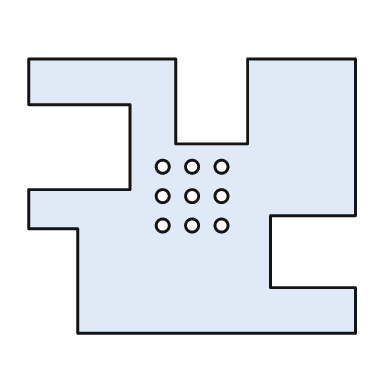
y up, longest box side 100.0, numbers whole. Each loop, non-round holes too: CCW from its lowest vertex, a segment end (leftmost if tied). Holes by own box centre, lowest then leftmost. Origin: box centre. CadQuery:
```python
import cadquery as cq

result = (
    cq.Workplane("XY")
    .moveTo(-35.0, -42.0)
    .lineTo(50.0, -42.0)
    .lineTo(50.0, -28.0)
    .lineTo(24.0, -28.0)
    .lineTo(24.0, -6.0)
    .lineTo(50.0, -6.0)
    .lineTo(50.0, 42.0)
    .lineTo(17.0, 42.0)
    .lineTo(17.0, 16.0)
    .lineTo(-5.0, 16.0)
    .lineTo(-5.0, 42.0)
    .lineTo(-50.0, 42.0)
    .lineTo(-50.0, 28.0)
    .lineTo(-19.0, 28.0)
    .lineTo(-19.0, 2.0)
    .lineTo(-50.0, 2.0)
    .lineTo(-50.0, -10.0)
    .lineTo(-35.0, -10.0)
    .close()
    .moveTo(-9.0, -9.0)
    .circle(2.0)
    .moveTo(0.0, -9.0)
    .circle(2.0)
    .moveTo(9.0, -9.0)
    .circle(2.0)
    .moveTo(-9.0, 0.0)
    .circle(2.0)
    .moveTo(0.0, 0.0)
    .circle(2.0)
    .moveTo(9.0, 0.0)
    .circle(2.0)
    .moveTo(-9.0, 9.0)
    .circle(2.0)
    .moveTo(0.0, 9.0)
    .circle(2.0)
    .moveTo(9.0, 9.0)
    .circle(2.0)
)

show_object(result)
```